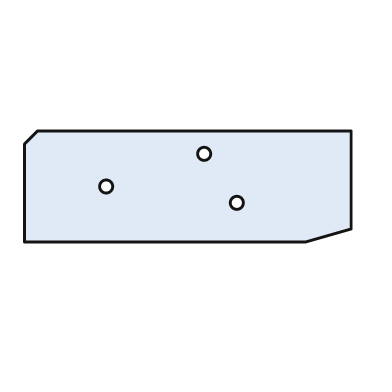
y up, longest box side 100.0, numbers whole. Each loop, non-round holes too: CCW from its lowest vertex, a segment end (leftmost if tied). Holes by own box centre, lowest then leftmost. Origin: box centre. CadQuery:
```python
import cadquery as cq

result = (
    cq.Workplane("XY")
    .moveTo(-50.0, -17.0)
    .lineTo(36.0, -17.0)
    .lineTo(50.0, -13.0)
    .lineTo(50.0, 17.0)
    .lineTo(-46.0, 17.0)
    .lineTo(-50.0, 13.0)
    .close()
    .moveTo(15.0, -5.0)
    .circle(2.0)
    .moveTo(-25.0, 0.0)
    .circle(2.0)
    .moveTo(5.0, 10.0)
    .circle(2.0)
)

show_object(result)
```